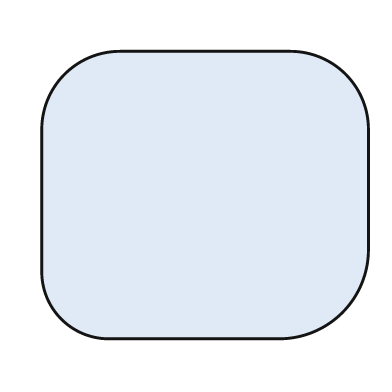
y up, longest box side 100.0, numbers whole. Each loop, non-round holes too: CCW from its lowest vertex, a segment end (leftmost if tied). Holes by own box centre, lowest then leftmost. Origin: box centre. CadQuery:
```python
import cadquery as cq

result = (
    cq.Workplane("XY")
    .moveTo(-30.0, -44.0)
    .lineTo(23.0, -44.0)
    .threePointArc((42.0, -36.0), (50.0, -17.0))
    .lineTo(50.0, 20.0)
    .threePointArc((43.0, 37.0), (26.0, 44.0))
    .lineTo(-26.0, 44.0)
    .threePointArc((-43.0, 37.0), (-50.0, 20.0))
    .lineTo(-50.0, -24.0)
    .threePointArc((-44.0, -38.0), (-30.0, -44.0))
    .close()
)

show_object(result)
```